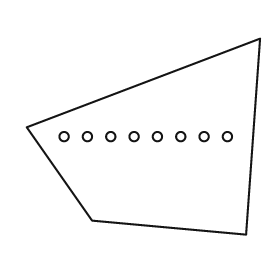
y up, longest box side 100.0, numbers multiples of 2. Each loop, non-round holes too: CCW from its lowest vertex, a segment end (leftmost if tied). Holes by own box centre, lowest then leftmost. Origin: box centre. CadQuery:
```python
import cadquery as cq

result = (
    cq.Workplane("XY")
    .moveTo(44.0, -42.0)
    .lineTo(50.0, 42.0)
    .lineTo(-50.0, 4.0)
    .lineTo(-22.0, -36.0)
    .close()
    .moveTo(-34.0, 0.0)
    .circle(2.0)
    .moveTo(-24.0, 0.0)
    .circle(2.0)
    .moveTo(-14.0, 0.0)
    .circle(2.0)
    .moveTo(-4.0, 0.0)
    .circle(2.0)
    .moveTo(6.0, 0.0)
    .circle(2.0)
    .moveTo(16.0, 0.0)
    .circle(2.0)
    .moveTo(26.0, 0.0)
    .circle(2.0)
    .moveTo(36.0, 0.0)
    .circle(2.0)
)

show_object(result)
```